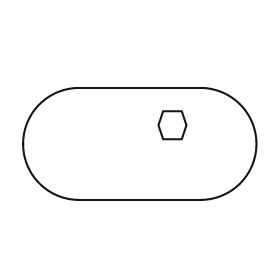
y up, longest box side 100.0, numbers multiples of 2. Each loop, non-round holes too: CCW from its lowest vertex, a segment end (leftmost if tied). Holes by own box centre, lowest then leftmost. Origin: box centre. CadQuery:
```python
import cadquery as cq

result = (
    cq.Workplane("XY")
    .moveTo(-26.0, -24.0)
    .lineTo(26.0, -24.0)
    .threePointArc((50.0, 0.0), (26.0, 24.0))
    .lineTo(-26.0, 24.0)
    .threePointArc((-50.0, 0.0), (-26.0, -24.0))
    .close()
    .moveTo(10.0, 2.0)
    .lineTo(18.0, 2.0)
    .lineTo(20.0, 8.0)
    .lineTo(18.0, 14.0)
    .lineTo(10.0, 14.0)
    .lineTo(8.0, 8.0)
    .close()
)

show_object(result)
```